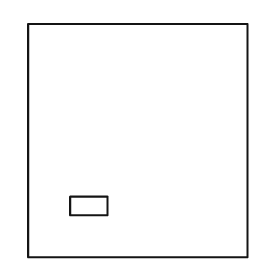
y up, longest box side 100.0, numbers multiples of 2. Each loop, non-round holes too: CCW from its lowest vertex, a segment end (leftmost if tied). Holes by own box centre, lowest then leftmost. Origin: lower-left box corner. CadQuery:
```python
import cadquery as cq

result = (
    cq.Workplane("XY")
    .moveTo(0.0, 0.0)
    .lineTo(94.0, 0.0)
    .lineTo(94.0, 100.0)
    .lineTo(0.0, 100.0)
    .close()
    .moveTo(18.0, 18.0)
    .lineTo(34.0, 18.0)
    .lineTo(34.0, 26.0)
    .lineTo(18.0, 26.0)
    .close()
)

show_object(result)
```